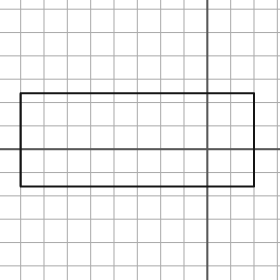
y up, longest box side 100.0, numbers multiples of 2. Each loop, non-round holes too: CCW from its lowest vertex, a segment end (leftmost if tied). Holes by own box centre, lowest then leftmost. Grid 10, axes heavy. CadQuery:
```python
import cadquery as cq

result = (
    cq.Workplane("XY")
    .moveTo(-80.0, -16.0)
    .lineTo(20.0, -16.0)
    .lineTo(20.0, 24.0)
    .lineTo(-80.0, 24.0)
    .close()
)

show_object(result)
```